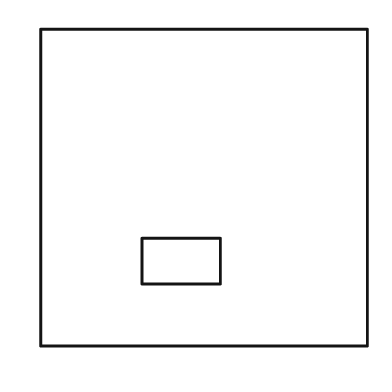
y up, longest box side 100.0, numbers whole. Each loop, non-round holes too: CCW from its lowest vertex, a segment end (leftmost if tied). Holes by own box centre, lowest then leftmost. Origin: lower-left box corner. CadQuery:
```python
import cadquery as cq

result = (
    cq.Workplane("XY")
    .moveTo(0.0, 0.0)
    .lineTo(100.0, 0.0)
    .lineTo(100.0, 97.0)
    .lineTo(0.0, 97.0)
    .close()
    .moveTo(31.0, 19.0)
    .lineTo(55.0, 19.0)
    .lineTo(55.0, 33.0)
    .lineTo(31.0, 33.0)
    .close()
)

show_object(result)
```